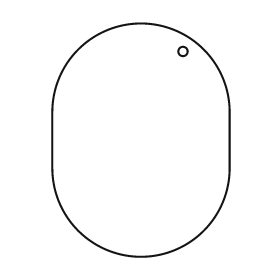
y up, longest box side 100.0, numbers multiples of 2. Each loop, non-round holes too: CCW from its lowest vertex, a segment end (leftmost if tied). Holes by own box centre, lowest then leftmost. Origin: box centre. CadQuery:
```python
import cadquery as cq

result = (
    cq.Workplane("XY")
    .moveTo(-38.0, -12.0)
    .threePointArc((0.0, -50.0), (38.0, -12.0))
    .lineTo(38.0, 12.0)
    .threePointArc((0.0, 50.0), (-38.0, 12.0))
    .close()
    .moveTo(18.0, 38.0)
    .circle(2.0)
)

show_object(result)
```